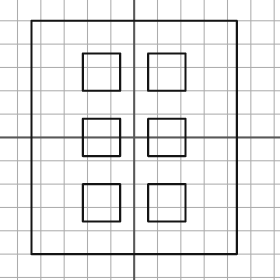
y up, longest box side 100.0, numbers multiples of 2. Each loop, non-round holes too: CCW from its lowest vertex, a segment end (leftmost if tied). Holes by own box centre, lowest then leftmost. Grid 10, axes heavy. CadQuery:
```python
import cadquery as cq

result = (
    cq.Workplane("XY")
    .moveTo(-44.0, -50.0)
    .lineTo(44.0, -50.0)
    .lineTo(44.0, 50.0)
    .lineTo(-44.0, 50.0)
    .close()
    .moveTo(-22.0, -36.0)
    .lineTo(-6.0, -36.0)
    .lineTo(-6.0, -20.0)
    .lineTo(-22.0, -20.0)
    .close()
    .moveTo(6.0, -36.0)
    .lineTo(22.0, -36.0)
    .lineTo(22.0, -20.0)
    .lineTo(6.0, -20.0)
    .close()
    .moveTo(-22.0, -8.0)
    .lineTo(-6.0, -8.0)
    .lineTo(-6.0, 8.0)
    .lineTo(-22.0, 8.0)
    .close()
    .moveTo(6.0, -8.0)
    .lineTo(22.0, -8.0)
    .lineTo(22.0, 8.0)
    .lineTo(6.0, 8.0)
    .close()
    .moveTo(-22.0, 20.0)
    .lineTo(-6.0, 20.0)
    .lineTo(-6.0, 36.0)
    .lineTo(-22.0, 36.0)
    .close()
    .moveTo(6.0, 20.0)
    .lineTo(22.0, 20.0)
    .lineTo(22.0, 36.0)
    .lineTo(6.0, 36.0)
    .close()
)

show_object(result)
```